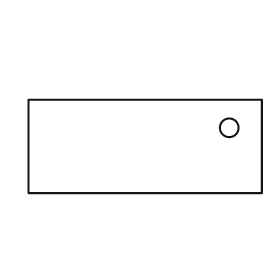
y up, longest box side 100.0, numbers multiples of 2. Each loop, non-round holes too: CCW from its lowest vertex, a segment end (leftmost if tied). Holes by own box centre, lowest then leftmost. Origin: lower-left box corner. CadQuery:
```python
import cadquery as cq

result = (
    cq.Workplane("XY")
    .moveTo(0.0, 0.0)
    .lineTo(100.0, 0.0)
    .lineTo(100.0, 40.0)
    .lineTo(0.0, 40.0)
    .close()
    .moveTo(86.0, 28.0)
    .circle(4.0)
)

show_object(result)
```